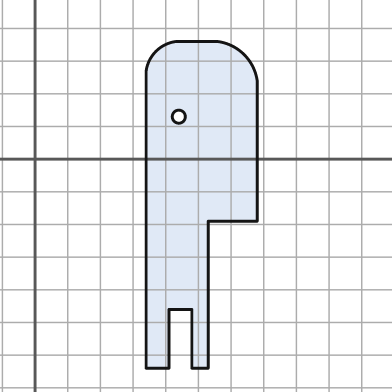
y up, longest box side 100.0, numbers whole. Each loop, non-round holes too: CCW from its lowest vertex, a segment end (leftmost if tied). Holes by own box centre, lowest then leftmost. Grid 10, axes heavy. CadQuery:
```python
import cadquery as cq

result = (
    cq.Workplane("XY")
    .moveTo(34.0, -64.0)
    .lineTo(41.0, -64.0)
    .lineTo(41.0, -46.0)
    .lineTo(48.0, -46.0)
    .lineTo(48.0, -64.0)
    .lineTo(53.0, -64.0)
    .lineTo(53.0, -19.0)
    .lineTo(68.0, -19.0)
    .lineTo(68.0, 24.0)
    .threePointArc((64.0, 32.0), (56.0, 36.0))
    .lineTo(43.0, 36.0)
    .threePointArc((37.0, 33.0), (34.0, 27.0))
    .close()
    .moveTo(44.0, 13.0)
    .circle(2.0)
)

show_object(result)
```